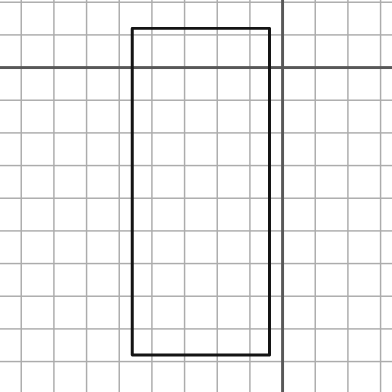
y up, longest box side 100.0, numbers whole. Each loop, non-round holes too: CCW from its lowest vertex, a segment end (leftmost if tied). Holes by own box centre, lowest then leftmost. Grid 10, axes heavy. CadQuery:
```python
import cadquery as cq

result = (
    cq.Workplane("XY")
    .moveTo(-46.0, -88.0)
    .lineTo(-4.0, -88.0)
    .lineTo(-4.0, 12.0)
    .lineTo(-46.0, 12.0)
    .close()
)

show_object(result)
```